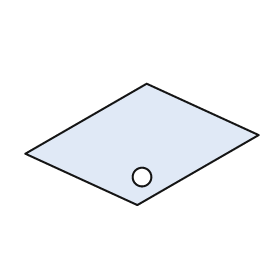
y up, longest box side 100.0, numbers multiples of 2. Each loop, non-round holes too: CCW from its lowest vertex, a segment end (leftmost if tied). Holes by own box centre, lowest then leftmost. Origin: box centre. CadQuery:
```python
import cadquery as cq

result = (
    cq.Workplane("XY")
    .moveTo(-2.0, -26.0)
    .lineTo(50.0, 4.0)
    .lineTo(2.0, 26.0)
    .lineTo(-50.0, -4.0)
    .close()
    .moveTo(0.0, -14.0)
    .circle(4.0)
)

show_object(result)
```